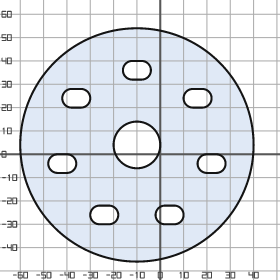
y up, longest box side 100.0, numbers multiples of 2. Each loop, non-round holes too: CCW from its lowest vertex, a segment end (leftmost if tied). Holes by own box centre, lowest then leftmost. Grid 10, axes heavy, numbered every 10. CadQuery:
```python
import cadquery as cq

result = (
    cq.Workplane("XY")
    .moveTo(-10.0, 4.0)
    .circle(50.0)
    .moveTo(-26.0, -30.0)
    .lineTo(-22.0, -30.0)
    .threePointArc((-18.0, -26.0), (-22.0, -22.0))
    .lineTo(-26.0, -22.0)
    .threePointArc((-30.0, -26.0), (-26.0, -30.0))
    .close()
    .moveTo(2.0, -30.0)
    .lineTo(6.0, -30.0)
    .threePointArc((10.0, -26.0), (6.0, -22.0))
    .lineTo(2.0, -22.0)
    .threePointArc((-2.0, -26.0), (2.0, -30.0))
    .close()
    .moveTo(-44.0, -8.0)
    .lineTo(-40.0, -8.0)
    .threePointArc((-36.0, -4.0), (-40.0, 0.0))
    .lineTo(-44.0, 0.0)
    .threePointArc((-48.0, -4.0), (-44.0, -8.0))
    .close()
    .moveTo(20.0, -8.0)
    .lineTo(24.0, -8.0)
    .threePointArc((28.0, -4.0), (24.0, 0.0))
    .lineTo(20.0, 0.0)
    .threePointArc((16.0, -4.0), (20.0, -8.0))
    .close()
    .moveTo(-10.0, 4.0)
    .circle(10.0)
    .moveTo(-38.0, 20.0)
    .lineTo(-34.0, 20.0)
    .threePointArc((-30.0, 24.0), (-34.0, 28.0))
    .lineTo(-38.0, 28.0)
    .threePointArc((-42.0, 24.0), (-38.0, 20.0))
    .close()
    .moveTo(14.0, 20.0)
    .lineTo(18.0, 20.0)
    .threePointArc((22.0, 24.0), (18.0, 28.0))
    .lineTo(14.0, 28.0)
    .threePointArc((10.0, 24.0), (14.0, 20.0))
    .close()
    .moveTo(-12.0, 32.0)
    .lineTo(-8.0, 32.0)
    .threePointArc((-4.0, 36.0), (-8.0, 40.0))
    .lineTo(-12.0, 40.0)
    .threePointArc((-16.0, 36.0), (-12.0, 32.0))
    .close()
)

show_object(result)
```